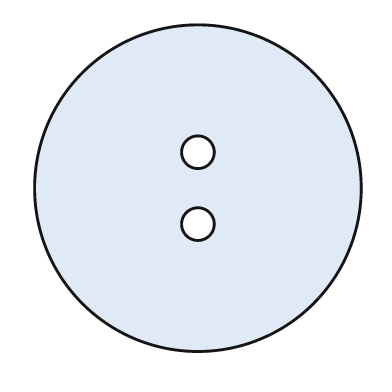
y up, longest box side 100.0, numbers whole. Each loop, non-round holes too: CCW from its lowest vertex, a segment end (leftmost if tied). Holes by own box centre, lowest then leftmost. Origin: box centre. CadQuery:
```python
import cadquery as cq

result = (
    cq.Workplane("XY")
    .moveTo(0.0, 0.0)
    .circle(50.0)
    .moveTo(0.0, -11.0)
    .circle(5.0)
    .moveTo(0.0, 11.0)
    .circle(5.0)
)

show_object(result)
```